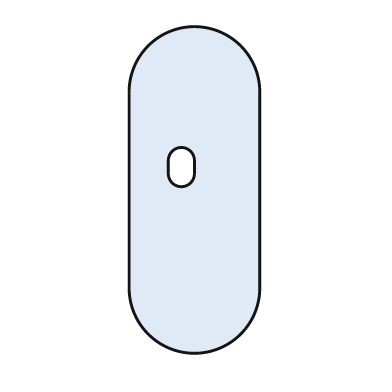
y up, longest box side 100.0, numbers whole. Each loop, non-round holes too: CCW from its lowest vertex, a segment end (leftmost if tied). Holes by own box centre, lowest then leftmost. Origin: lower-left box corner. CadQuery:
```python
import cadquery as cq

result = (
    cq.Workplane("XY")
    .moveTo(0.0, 20.0)
    .threePointArc((20.0, 0.0), (40.0, 20.0))
    .lineTo(40.0, 80.0)
    .threePointArc((20.0, 100.0), (0.0, 80.0))
    .close()
    .moveTo(12.0, 55.0)
    .threePointArc((16.0, 51.0), (20.0, 55.0))
    .lineTo(20.0, 59.0)
    .threePointArc((16.0, 63.0), (12.0, 59.0))
    .close()
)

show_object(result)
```